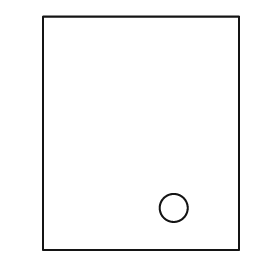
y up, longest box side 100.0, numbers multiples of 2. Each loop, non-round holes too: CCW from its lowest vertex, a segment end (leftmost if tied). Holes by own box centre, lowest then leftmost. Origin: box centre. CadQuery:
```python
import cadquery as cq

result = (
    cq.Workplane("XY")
    .moveTo(-42.0, -50.0)
    .lineTo(42.0, -50.0)
    .lineTo(42.0, 50.0)
    .lineTo(-42.0, 50.0)
    .close()
    .moveTo(14.0, -32.0)
    .circle(6.0)
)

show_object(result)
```